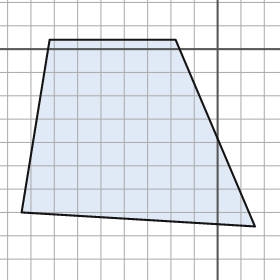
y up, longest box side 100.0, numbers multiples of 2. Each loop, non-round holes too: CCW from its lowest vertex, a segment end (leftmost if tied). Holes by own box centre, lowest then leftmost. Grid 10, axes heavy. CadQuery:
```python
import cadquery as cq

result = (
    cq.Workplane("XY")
    .moveTo(16.0, -76.0)
    .lineTo(-18.0, 4.0)
    .lineTo(-72.0, 4.0)
    .lineTo(-84.0, -70.0)
    .close()
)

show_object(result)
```